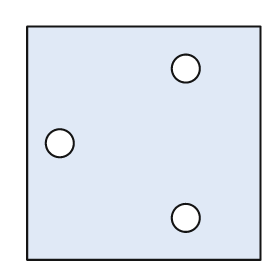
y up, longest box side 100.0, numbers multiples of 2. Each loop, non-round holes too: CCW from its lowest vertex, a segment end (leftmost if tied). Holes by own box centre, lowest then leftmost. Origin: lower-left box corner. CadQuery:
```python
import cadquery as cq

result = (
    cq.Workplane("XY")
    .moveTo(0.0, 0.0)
    .lineTo(100.0, 0.0)
    .lineTo(100.0, 100.0)
    .lineTo(0.0, 100.0)
    .close()
    .moveTo(68.0, 18.0)
    .circle(6.0)
    .moveTo(14.0, 50.0)
    .circle(6.0)
    .moveTo(68.0, 82.0)
    .circle(6.0)
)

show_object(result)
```